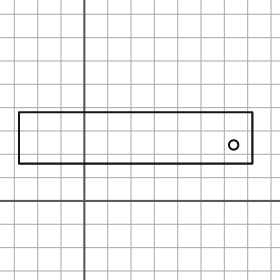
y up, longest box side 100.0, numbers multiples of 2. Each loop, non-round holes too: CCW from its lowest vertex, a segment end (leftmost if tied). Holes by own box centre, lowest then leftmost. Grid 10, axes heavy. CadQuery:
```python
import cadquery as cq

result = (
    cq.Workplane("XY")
    .moveTo(-28.0, 16.0)
    .lineTo(72.0, 16.0)
    .lineTo(72.0, 38.0)
    .lineTo(-28.0, 38.0)
    .close()
    .moveTo(64.0, 24.0)
    .circle(2.0)
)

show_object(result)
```